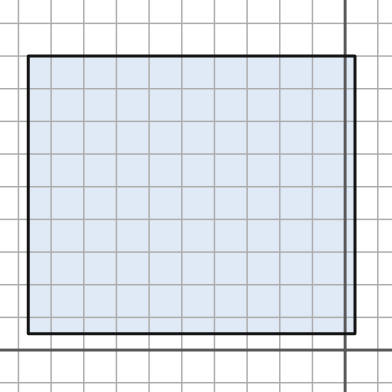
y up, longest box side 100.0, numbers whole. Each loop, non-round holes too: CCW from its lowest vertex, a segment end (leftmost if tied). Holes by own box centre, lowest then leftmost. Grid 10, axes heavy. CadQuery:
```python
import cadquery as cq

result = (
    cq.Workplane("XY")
    .moveTo(-97.0, 5.0)
    .lineTo(3.0, 5.0)
    .lineTo(3.0, 90.0)
    .lineTo(-97.0, 90.0)
    .close()
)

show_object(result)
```